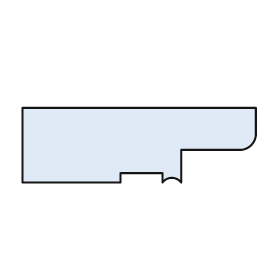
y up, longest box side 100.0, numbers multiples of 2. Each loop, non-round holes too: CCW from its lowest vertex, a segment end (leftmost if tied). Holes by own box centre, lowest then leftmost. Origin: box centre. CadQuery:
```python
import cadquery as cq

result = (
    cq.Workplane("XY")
    .moveTo(-50.0, -16.0)
    .lineTo(-8.0, -16.0)
    .lineTo(-8.0, -12.0)
    .lineTo(10.0, -12.0)
    .lineTo(10.0, -16.0)
    .threePointArc((14.0, -14.0), (18.0, -16.0))
    .lineTo(18.0, -2.0)
    .lineTo(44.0, -2.0)
    .threePointArc((48.0, 0.0), (50.0, 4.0))
    .lineTo(50.0, 16.0)
    .lineTo(-50.0, 16.0)
    .close()
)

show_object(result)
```